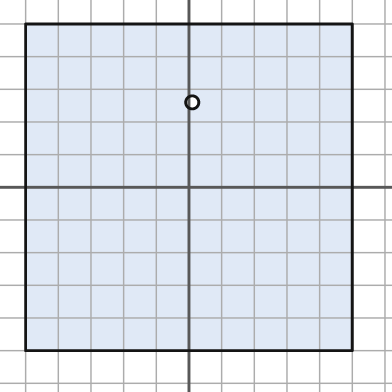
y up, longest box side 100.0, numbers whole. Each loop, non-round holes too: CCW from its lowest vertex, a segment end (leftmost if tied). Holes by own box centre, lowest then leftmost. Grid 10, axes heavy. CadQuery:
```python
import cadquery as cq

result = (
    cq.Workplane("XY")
    .moveTo(-50.0, -50.0)
    .lineTo(50.0, -50.0)
    .lineTo(50.0, 50.0)
    .lineTo(-50.0, 50.0)
    .close()
    .moveTo(1.0, 26.0)
    .circle(2.0)
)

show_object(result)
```